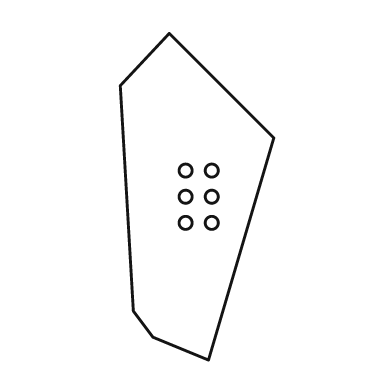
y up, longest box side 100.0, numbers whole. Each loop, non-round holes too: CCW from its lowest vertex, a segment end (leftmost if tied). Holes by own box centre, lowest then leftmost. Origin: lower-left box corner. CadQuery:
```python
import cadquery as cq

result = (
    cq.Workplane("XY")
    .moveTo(27.0, 0.0)
    .lineTo(47.0, 68.0)
    .lineTo(15.0, 100.0)
    .lineTo(0.0, 84.0)
    .lineTo(4.0, 15.0)
    .lineTo(10.0, 7.0)
    .close()
    .moveTo(20.0, 42.0)
    .circle(2.0)
    .moveTo(28.0, 42.0)
    .circle(2.0)
    .moveTo(20.0, 50.0)
    .circle(2.0)
    .moveTo(28.0, 50.0)
    .circle(2.0)
    .moveTo(20.0, 58.0)
    .circle(2.0)
    .moveTo(28.0, 58.0)
    .circle(2.0)
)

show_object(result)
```